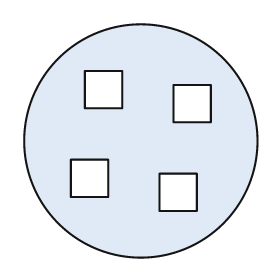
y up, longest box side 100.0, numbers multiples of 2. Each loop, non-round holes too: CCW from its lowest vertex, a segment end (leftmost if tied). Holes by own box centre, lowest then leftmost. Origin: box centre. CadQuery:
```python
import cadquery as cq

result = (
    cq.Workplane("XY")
    .moveTo(0.0, 0.0)
    .circle(50.0)
    .moveTo(8.0, -30.0)
    .lineTo(24.0, -30.0)
    .lineTo(24.0, -14.0)
    .lineTo(8.0, -14.0)
    .close()
    .moveTo(-30.0, -24.0)
    .lineTo(-14.0, -24.0)
    .lineTo(-14.0, -8.0)
    .lineTo(-30.0, -8.0)
    .close()
    .moveTo(14.0, 8.0)
    .lineTo(30.0, 8.0)
    .lineTo(30.0, 24.0)
    .lineTo(14.0, 24.0)
    .close()
    .moveTo(-24.0, 14.0)
    .lineTo(-8.0, 14.0)
    .lineTo(-8.0, 30.0)
    .lineTo(-24.0, 30.0)
    .close()
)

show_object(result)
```